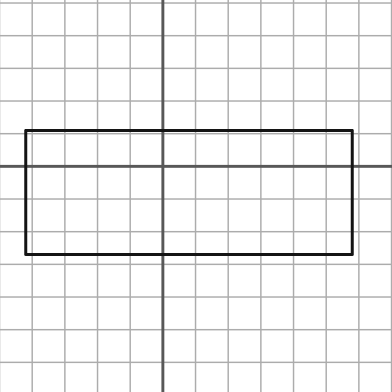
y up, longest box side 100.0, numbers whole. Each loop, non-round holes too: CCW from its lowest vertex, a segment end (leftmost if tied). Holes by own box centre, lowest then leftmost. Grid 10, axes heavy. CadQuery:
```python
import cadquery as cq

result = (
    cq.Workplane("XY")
    .moveTo(-42.0, -27.0)
    .lineTo(58.0, -27.0)
    .lineTo(58.0, 11.0)
    .lineTo(-42.0, 11.0)
    .close()
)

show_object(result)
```